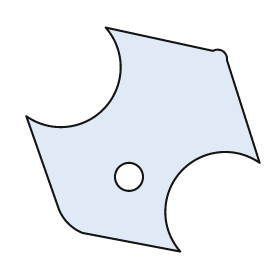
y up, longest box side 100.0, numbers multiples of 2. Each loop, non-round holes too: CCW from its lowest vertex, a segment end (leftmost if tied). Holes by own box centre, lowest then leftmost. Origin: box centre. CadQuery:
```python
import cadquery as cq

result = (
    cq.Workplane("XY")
    .moveTo(16.0, -48.0)
    .threePointArc((16.0, -14.0), (50.0, -10.0))
    .lineTo(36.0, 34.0)
    .threePointArc((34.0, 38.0), (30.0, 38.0))
    .lineTo(-16.0, 48.0)
    .threePointArc((-16.0, 14.0), (-50.0, 10.0))
    .lineTo(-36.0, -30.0)
    .threePointArc((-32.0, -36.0), (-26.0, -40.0))
    .close()
    .moveTo(-6.0, -16.0)
    .circle(6.0)
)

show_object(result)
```